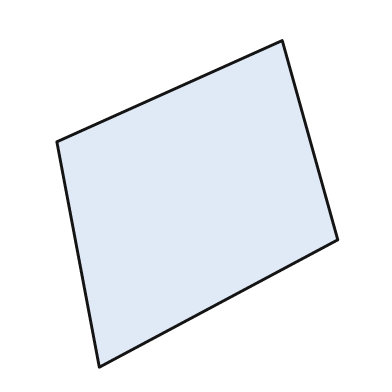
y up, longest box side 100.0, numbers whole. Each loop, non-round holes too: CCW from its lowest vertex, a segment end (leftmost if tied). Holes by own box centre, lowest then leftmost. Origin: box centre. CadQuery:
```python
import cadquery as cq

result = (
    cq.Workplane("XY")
    .moveTo(-30.0, -50.0)
    .lineTo(43.0, -11.0)
    .lineTo(26.0, 50.0)
    .lineTo(-43.0, 19.0)
    .close()
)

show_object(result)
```